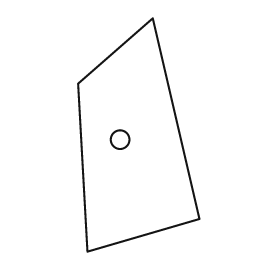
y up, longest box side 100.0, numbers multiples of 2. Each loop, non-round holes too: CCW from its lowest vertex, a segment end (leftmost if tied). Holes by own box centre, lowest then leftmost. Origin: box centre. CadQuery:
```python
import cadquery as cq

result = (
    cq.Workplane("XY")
    .moveTo(-22.0, -50.0)
    .lineTo(26.0, -36.0)
    .lineTo(6.0, 50.0)
    .lineTo(-26.0, 22.0)
    .close()
    .moveTo(-8.0, -2.0)
    .circle(4.0)
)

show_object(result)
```